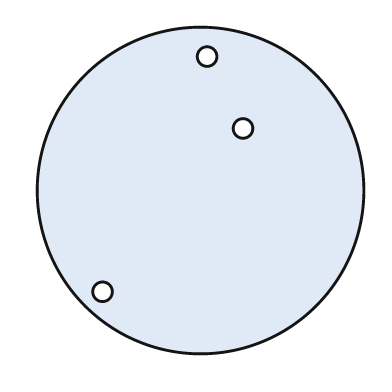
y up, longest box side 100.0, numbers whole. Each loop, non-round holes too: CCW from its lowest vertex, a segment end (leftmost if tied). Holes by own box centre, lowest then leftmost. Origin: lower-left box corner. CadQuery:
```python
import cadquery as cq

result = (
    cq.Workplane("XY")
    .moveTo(50.0, 50.0)
    .circle(50.0)
    .moveTo(20.0, 19.0)
    .circle(3.0)
    .moveTo(63.0, 69.0)
    .circle(3.0)
    .moveTo(52.0, 91.0)
    .circle(3.0)
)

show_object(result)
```